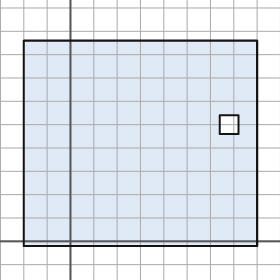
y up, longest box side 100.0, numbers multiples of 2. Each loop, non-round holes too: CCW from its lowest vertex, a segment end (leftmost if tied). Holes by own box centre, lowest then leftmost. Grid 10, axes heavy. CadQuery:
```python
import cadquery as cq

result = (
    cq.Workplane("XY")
    .moveTo(-20.0, -2.0)
    .lineTo(80.0, -2.0)
    .lineTo(80.0, 86.0)
    .lineTo(-20.0, 86.0)
    .close()
    .moveTo(64.0, 46.0)
    .lineTo(72.0, 46.0)
    .lineTo(72.0, 54.0)
    .lineTo(64.0, 54.0)
    .close()
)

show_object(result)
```